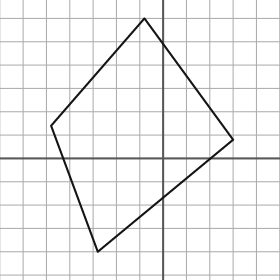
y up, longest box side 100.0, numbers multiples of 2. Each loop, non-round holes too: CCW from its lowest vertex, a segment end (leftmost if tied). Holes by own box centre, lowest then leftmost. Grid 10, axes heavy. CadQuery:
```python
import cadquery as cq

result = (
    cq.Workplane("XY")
    .moveTo(-28.0, -40.0)
    .lineTo(30.0, 8.0)
    .lineTo(-8.0, 60.0)
    .lineTo(-48.0, 14.0)
    .close()
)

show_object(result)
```